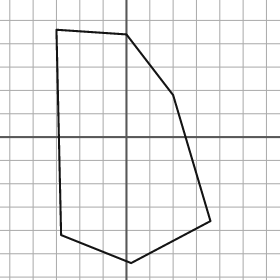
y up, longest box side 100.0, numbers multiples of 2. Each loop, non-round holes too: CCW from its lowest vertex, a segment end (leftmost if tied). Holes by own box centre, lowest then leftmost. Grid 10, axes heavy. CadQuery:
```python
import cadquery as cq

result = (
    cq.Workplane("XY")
    .moveTo(2.0, -54.0)
    .lineTo(36.0, -36.0)
    .lineTo(20.0, 18.0)
    .lineTo(0.0, 44.0)
    .lineTo(-30.0, 46.0)
    .lineTo(-28.0, -42.0)
    .close()
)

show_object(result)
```